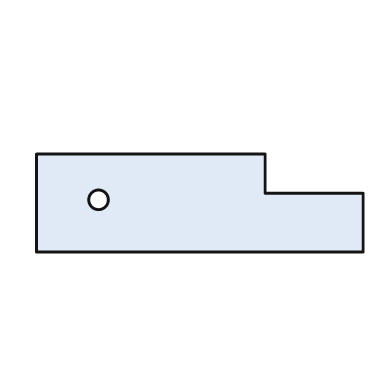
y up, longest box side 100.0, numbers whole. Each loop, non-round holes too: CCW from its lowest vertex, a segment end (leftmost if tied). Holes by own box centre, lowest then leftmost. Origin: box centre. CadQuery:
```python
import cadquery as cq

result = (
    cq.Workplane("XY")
    .moveTo(-50.0, -15.0)
    .lineTo(50.0, -15.0)
    .lineTo(50.0, 3.0)
    .lineTo(20.0, 3.0)
    .lineTo(20.0, 15.0)
    .lineTo(-50.0, 15.0)
    .close()
    .moveTo(-31.0, 1.0)
    .circle(3.0)
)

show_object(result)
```